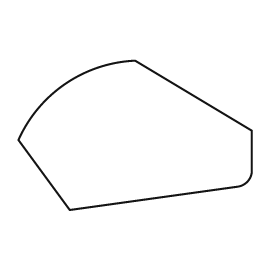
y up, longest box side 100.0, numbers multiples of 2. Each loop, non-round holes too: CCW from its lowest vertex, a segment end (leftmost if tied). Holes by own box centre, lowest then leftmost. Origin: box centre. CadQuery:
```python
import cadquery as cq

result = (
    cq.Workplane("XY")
    .moveTo(-28.0, -32.0)
    .lineTo(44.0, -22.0)
    .threePointArc((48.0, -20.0), (50.0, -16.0))
    .lineTo(50.0, 2.0)
    .lineTo(0.0, 32.0)
    .threePointArc((-30.0, 22.0), (-50.0, -2.0))
    .close()
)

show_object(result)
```